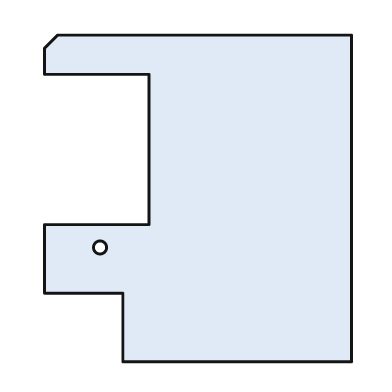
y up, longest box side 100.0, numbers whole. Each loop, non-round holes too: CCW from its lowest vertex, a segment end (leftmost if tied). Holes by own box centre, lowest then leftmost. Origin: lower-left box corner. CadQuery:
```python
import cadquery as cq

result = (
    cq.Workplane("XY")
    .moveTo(24.0, 0.0)
    .lineTo(94.0, 0.0)
    .lineTo(94.0, 100.0)
    .lineTo(4.0, 100.0)
    .lineTo(0.0, 96.0)
    .lineTo(0.0, 88.0)
    .lineTo(32.0, 88.0)
    .lineTo(32.0, 42.0)
    .lineTo(0.0, 42.0)
    .lineTo(0.0, 21.0)
    .lineTo(24.0, 21.0)
    .close()
    .moveTo(17.0, 35.0)
    .circle(2.0)
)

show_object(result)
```